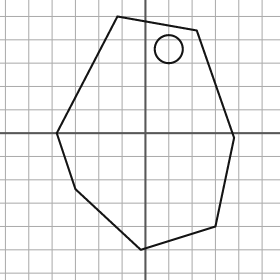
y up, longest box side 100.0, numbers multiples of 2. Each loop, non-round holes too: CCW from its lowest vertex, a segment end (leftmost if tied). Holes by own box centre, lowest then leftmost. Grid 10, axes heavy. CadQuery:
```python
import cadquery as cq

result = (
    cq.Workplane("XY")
    .moveTo(-2.0, -50.0)
    .lineTo(30.0, -40.0)
    .lineTo(38.0, -2.0)
    .lineTo(22.0, 44.0)
    .lineTo(-12.0, 50.0)
    .lineTo(-38.0, 0.0)
    .lineTo(-30.0, -24.0)
    .close()
    .moveTo(10.0, 36.0)
    .circle(6.0)
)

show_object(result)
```